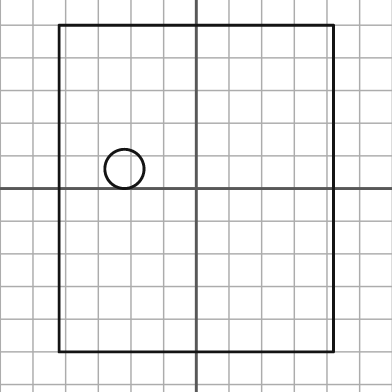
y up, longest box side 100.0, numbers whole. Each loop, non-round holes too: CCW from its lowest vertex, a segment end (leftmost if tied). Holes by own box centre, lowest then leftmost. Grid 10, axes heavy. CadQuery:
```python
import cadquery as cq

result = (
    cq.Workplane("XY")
    .moveTo(-42.0, -50.0)
    .lineTo(42.0, -50.0)
    .lineTo(42.0, 50.0)
    .lineTo(-42.0, 50.0)
    .close()
    .moveTo(-22.0, 6.0)
    .circle(6.0)
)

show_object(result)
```